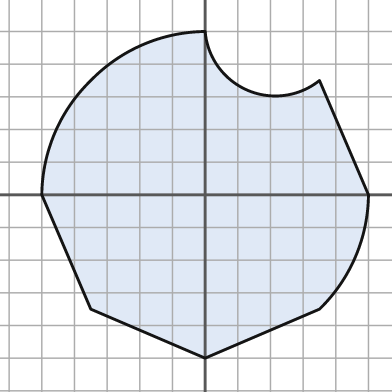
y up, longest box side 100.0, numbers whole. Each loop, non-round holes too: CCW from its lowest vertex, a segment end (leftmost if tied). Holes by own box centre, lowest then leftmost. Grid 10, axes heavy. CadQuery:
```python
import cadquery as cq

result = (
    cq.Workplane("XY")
    .moveTo(0.0, -50.0)
    .lineTo(35.0, -35.0)
    .threePointArc((46.0, -19.0), (50.0, 0.0))
    .lineTo(35.0, 35.0)
    .threePointArc((13.0, 32.0), (0.0, 50.0))
    .threePointArc((-19.0, 46.0), (-35.0, 35.0))
    .threePointArc((-46.0, 19.0), (-50.0, 0.0))
    .lineTo(-35.0, -35.0)
    .close()
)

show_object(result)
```